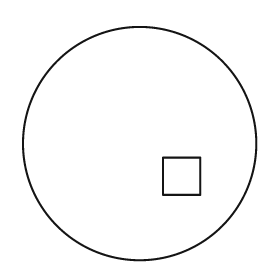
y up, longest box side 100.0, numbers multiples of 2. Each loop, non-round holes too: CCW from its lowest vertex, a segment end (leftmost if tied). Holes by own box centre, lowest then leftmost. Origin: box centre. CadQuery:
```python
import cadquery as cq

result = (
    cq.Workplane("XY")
    .moveTo(0.0, 0.0)
    .circle(50.0)
    .moveTo(10.0, -22.0)
    .lineTo(26.0, -22.0)
    .lineTo(26.0, -6.0)
    .lineTo(10.0, -6.0)
    .close()
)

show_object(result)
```